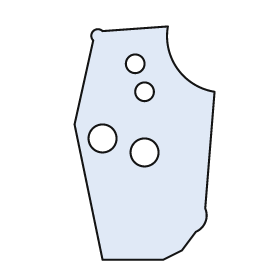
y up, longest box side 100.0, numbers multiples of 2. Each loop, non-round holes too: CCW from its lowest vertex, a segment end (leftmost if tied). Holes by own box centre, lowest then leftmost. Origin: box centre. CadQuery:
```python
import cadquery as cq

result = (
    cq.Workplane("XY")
    .moveTo(-18.0, -50.0)
    .lineTo(8.0, -50.0)
    .lineTo(16.0, -46.0)
    .lineTo(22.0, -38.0)
    .threePointArc((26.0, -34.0), (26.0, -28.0))
    .lineTo(30.0, 22.0)
    .threePointArc((14.0, 32.0), (10.0, 50.0))
    .lineTo(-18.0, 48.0)
    .threePointArc((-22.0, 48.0), (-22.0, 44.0))
    .lineTo(-30.0, 8.0)
    .close()
    .moveTo(0.0, -4.0)
    .circle(6.0)
    .moveTo(-18.0, 2.0)
    .circle(6.0)
    .moveTo(0.0, 22.0)
    .circle(4.0)
    .moveTo(-4.0, 34.0)
    .circle(4.0)
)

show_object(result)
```